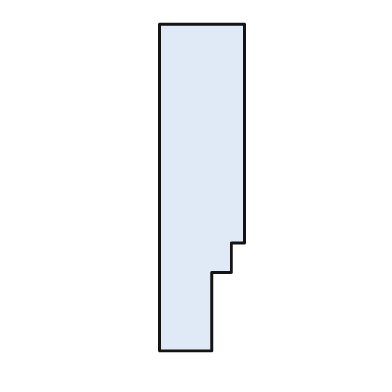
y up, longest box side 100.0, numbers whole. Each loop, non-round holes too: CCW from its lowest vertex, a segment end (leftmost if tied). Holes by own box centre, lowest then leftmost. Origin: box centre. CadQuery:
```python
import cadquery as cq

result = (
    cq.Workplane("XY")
    .moveTo(-13.0, -50.0)
    .lineTo(3.0, -50.0)
    .lineTo(3.0, -26.0)
    .lineTo(9.0, -26.0)
    .lineTo(9.0, -17.0)
    .lineTo(13.0, -17.0)
    .lineTo(13.0, 50.0)
    .lineTo(-13.0, 50.0)
    .close()
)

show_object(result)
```